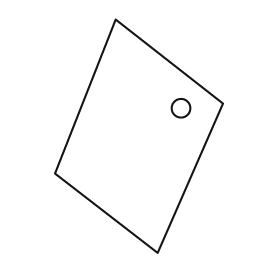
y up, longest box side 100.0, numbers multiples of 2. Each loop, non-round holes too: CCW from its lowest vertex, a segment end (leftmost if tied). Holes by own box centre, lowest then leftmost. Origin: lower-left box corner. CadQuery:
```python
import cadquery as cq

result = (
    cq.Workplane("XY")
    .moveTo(44.0, 0.0)
    .lineTo(72.0, 64.0)
    .lineTo(26.0, 100.0)
    .lineTo(0.0, 34.0)
    .close()
    .moveTo(54.0, 62.0)
    .circle(4.0)
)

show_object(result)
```